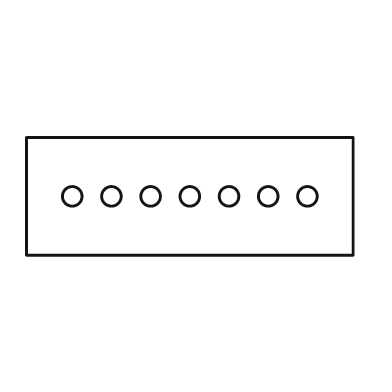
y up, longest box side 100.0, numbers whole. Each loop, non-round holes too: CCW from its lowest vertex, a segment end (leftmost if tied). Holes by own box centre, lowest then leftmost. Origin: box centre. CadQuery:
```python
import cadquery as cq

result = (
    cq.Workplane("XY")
    .moveTo(-50.0, -18.0)
    .lineTo(50.0, -18.0)
    .lineTo(50.0, 18.0)
    .lineTo(-50.0, 18.0)
    .close()
    .moveTo(-36.0, 0.0)
    .circle(3.0)
    .moveTo(-24.0, 0.0)
    .circle(3.0)
    .moveTo(-12.0, 0.0)
    .circle(3.0)
    .moveTo(0.0, 0.0)
    .circle(3.0)
    .moveTo(12.0, 0.0)
    .circle(3.0)
    .moveTo(24.0, 0.0)
    .circle(3.0)
    .moveTo(36.0, 0.0)
    .circle(3.0)
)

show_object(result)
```